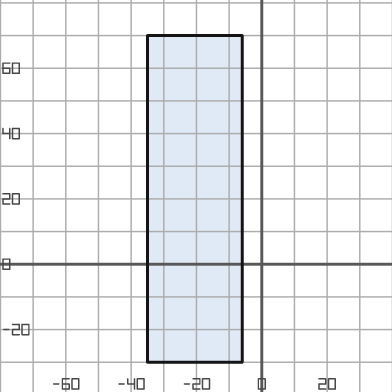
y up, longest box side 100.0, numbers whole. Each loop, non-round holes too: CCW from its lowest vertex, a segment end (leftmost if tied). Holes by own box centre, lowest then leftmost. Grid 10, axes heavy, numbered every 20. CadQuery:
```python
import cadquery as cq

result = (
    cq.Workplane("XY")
    .moveTo(-35.0, -30.0)
    .lineTo(-6.0, -30.0)
    .lineTo(-6.0, 70.0)
    .lineTo(-35.0, 70.0)
    .close()
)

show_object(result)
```